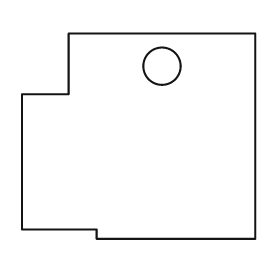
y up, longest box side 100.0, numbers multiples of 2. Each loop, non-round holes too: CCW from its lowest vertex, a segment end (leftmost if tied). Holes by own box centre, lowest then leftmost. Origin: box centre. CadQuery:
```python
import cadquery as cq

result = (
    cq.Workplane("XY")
    .moveTo(-18.0, -44.0)
    .lineTo(50.0, -44.0)
    .lineTo(50.0, 44.0)
    .lineTo(-30.0, 44.0)
    .lineTo(-30.0, 18.0)
    .lineTo(-50.0, 18.0)
    .lineTo(-50.0, -40.0)
    .lineTo(-18.0, -40.0)
    .close()
    .moveTo(10.0, 30.0)
    .circle(8.0)
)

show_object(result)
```